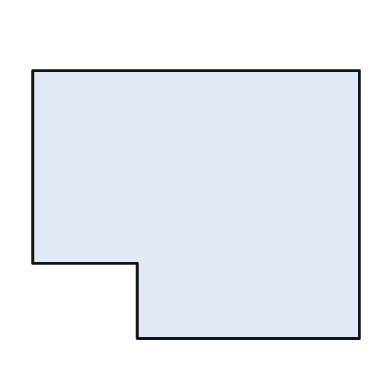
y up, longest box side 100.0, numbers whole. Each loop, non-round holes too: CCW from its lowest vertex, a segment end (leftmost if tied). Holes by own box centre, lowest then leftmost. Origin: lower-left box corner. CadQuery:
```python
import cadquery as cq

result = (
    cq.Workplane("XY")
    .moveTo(32.0, 0.0)
    .lineTo(100.0, 0.0)
    .lineTo(100.0, 82.0)
    .lineTo(0.0, 82.0)
    .lineTo(0.0, 23.0)
    .lineTo(32.0, 23.0)
    .close()
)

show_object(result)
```